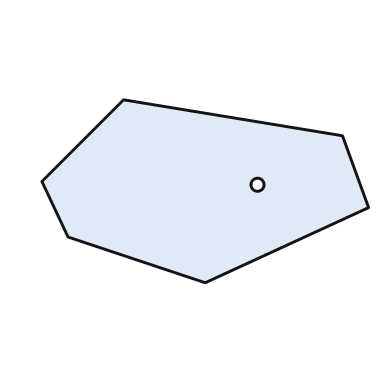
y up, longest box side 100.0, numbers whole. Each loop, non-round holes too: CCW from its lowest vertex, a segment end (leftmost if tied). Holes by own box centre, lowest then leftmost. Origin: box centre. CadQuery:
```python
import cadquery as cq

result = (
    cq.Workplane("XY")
    .moveTo(0.0, -28.0)
    .lineTo(50.0, -5.0)
    .lineTo(42.0, 17.0)
    .lineTo(-25.0, 28.0)
    .lineTo(-50.0, 3.0)
    .lineTo(-42.0, -14.0)
    .close()
    .moveTo(16.0, 2.0)
    .circle(2.0)
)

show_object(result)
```